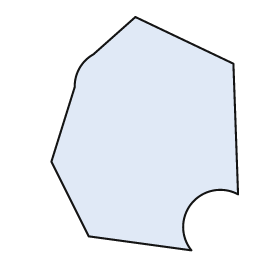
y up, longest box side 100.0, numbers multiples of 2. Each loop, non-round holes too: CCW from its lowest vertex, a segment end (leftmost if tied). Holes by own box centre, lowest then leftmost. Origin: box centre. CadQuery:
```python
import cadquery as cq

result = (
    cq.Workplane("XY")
    .moveTo(20.0, -50.0)
    .threePointArc((20.0, -30.0), (40.0, -26.0))
    .lineTo(38.0, 30.0)
    .lineTo(-4.0, 50.0)
    .lineTo(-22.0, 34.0)
    .threePointArc((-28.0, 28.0), (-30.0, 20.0))
    .lineTo(-40.0, -12.0)
    .lineTo(-24.0, -44.0)
    .close()
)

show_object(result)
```